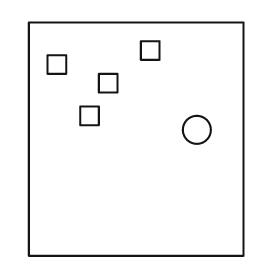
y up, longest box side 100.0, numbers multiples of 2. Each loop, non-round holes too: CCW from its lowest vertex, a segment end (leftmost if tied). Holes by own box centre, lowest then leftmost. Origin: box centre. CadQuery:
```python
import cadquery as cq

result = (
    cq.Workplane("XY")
    .moveTo(-46.0, -50.0)
    .lineTo(46.0, -50.0)
    .lineTo(46.0, 50.0)
    .lineTo(-46.0, 50.0)
    .close()
    .moveTo(26.0, 4.0)
    .circle(6.0)
    .moveTo(-24.0, 6.0)
    .lineTo(-16.0, 6.0)
    .lineTo(-16.0, 14.0)
    .lineTo(-24.0, 14.0)
    .close()
    .moveTo(-16.0, 20.0)
    .lineTo(-8.0, 20.0)
    .lineTo(-8.0, 28.0)
    .lineTo(-16.0, 28.0)
    .close()
    .moveTo(-38.0, 28.0)
    .lineTo(-30.0, 28.0)
    .lineTo(-30.0, 36.0)
    .lineTo(-38.0, 36.0)
    .close()
    .moveTo(2.0, 34.0)
    .lineTo(10.0, 34.0)
    .lineTo(10.0, 42.0)
    .lineTo(2.0, 42.0)
    .close()
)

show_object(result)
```